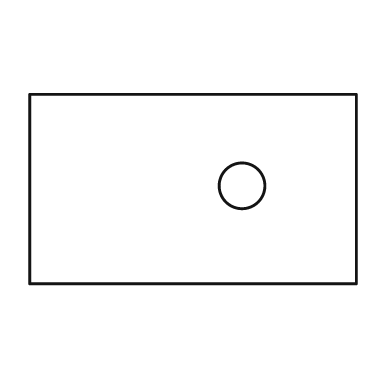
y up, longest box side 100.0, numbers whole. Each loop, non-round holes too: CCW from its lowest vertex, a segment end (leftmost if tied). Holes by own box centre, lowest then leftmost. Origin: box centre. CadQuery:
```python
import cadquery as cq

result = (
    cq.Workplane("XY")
    .moveTo(-50.0, -29.0)
    .lineTo(50.0, -29.0)
    .lineTo(50.0, 29.0)
    .lineTo(-50.0, 29.0)
    .close()
    .moveTo(15.0, 1.0)
    .circle(7.0)
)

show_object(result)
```